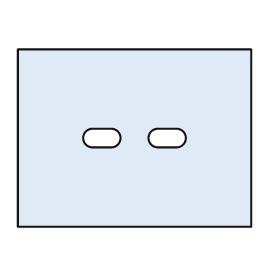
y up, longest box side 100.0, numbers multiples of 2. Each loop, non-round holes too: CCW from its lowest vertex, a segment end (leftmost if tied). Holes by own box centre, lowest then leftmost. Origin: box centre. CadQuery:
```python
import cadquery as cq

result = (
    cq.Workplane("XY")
    .moveTo(-50.0, -38.0)
    .lineTo(50.0, -38.0)
    .lineTo(50.0, 38.0)
    .lineTo(-50.0, 38.0)
    .close()
    .moveTo(-18.0, -4.0)
    .lineTo(-10.0, -4.0)
    .threePointArc((-6.0, 0.0), (-10.0, 4.0))
    .lineTo(-18.0, 4.0)
    .threePointArc((-22.0, 0.0), (-18.0, -4.0))
    .close()
    .moveTo(10.0, -4.0)
    .lineTo(18.0, -4.0)
    .threePointArc((22.0, 0.0), (18.0, 4.0))
    .lineTo(10.0, 4.0)
    .threePointArc((6.0, 0.0), (10.0, -4.0))
    .close()
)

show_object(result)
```